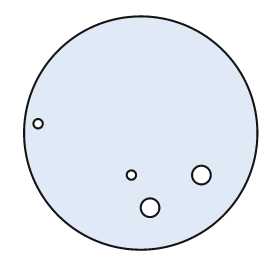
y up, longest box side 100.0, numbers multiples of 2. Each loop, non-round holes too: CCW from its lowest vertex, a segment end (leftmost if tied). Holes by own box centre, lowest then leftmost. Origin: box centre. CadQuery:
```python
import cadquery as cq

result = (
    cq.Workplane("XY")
    .moveTo(0.0, 0.0)
    .circle(50.0)
    .moveTo(4.0, -32.0)
    .circle(4.0)
    .moveTo(-4.0, -18.0)
    .circle(2.0)
    .moveTo(26.0, -18.0)
    .circle(4.0)
    .moveTo(-44.0, 4.0)
    .circle(2.0)
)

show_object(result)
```